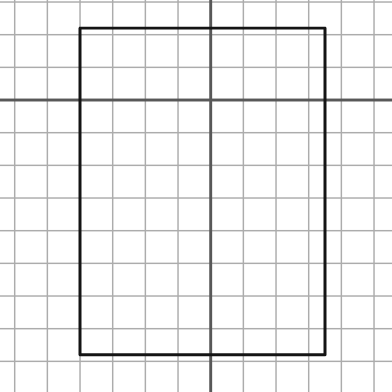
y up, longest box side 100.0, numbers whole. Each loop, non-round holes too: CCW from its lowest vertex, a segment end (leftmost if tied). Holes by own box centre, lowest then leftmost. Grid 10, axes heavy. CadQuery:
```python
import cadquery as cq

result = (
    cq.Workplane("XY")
    .moveTo(-40.0, -78.0)
    .lineTo(35.0, -78.0)
    .lineTo(35.0, 22.0)
    .lineTo(-40.0, 22.0)
    .close()
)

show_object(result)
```